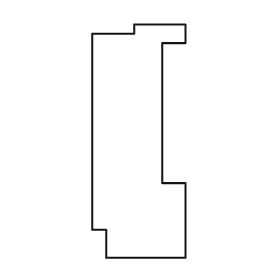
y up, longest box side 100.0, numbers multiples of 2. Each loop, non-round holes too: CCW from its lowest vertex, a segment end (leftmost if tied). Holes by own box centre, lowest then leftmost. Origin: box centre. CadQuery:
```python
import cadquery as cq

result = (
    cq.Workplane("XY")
    .moveTo(-14.0, -50.0)
    .lineTo(20.0, -50.0)
    .lineTo(20.0, -18.0)
    .lineTo(10.0, -18.0)
    .lineTo(10.0, 42.0)
    .lineTo(20.0, 42.0)
    .lineTo(20.0, 50.0)
    .lineTo(-2.0, 50.0)
    .lineTo(-2.0, 46.0)
    .lineTo(-20.0, 46.0)
    .lineTo(-20.0, -38.0)
    .lineTo(-14.0, -38.0)
    .close()
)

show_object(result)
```